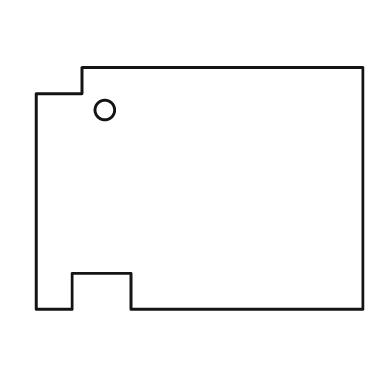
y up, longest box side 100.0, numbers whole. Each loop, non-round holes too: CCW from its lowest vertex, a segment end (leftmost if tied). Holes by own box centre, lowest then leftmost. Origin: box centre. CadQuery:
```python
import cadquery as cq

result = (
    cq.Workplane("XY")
    .moveTo(-50.0, -37.0)
    .lineTo(-39.0, -37.0)
    .lineTo(-39.0, -26.0)
    .lineTo(-21.0, -26.0)
    .lineTo(-21.0, -37.0)
    .lineTo(50.0, -37.0)
    .lineTo(50.0, 37.0)
    .lineTo(-36.0, 37.0)
    .lineTo(-36.0, 29.0)
    .lineTo(-50.0, 29.0)
    .close()
    .moveTo(-29.0, 24.0)
    .circle(3.0)
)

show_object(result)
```